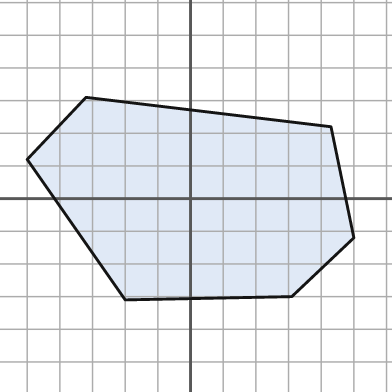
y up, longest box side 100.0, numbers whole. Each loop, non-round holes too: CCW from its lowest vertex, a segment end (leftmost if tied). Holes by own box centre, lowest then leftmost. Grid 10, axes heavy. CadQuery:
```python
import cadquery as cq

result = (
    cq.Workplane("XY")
    .moveTo(-20.0, -31.0)
    .lineTo(31.0, -30.0)
    .lineTo(50.0, -12.0)
    .lineTo(43.0, 22.0)
    .lineTo(-32.0, 31.0)
    .lineTo(-50.0, 12.0)
    .close()
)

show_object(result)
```